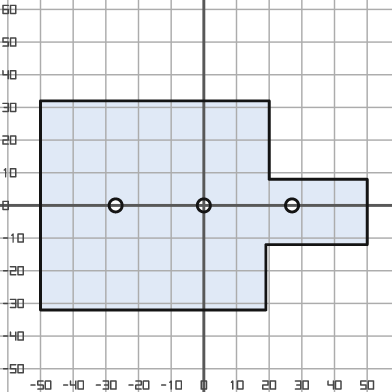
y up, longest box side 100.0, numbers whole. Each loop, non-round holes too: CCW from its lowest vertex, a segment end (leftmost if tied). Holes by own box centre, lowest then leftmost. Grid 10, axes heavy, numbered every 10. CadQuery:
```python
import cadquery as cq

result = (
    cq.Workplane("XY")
    .moveTo(-50.0, -32.0)
    .lineTo(19.0, -32.0)
    .lineTo(19.0, -12.0)
    .lineTo(50.0, -12.0)
    .lineTo(50.0, 8.0)
    .lineTo(20.0, 8.0)
    .lineTo(20.0, 32.0)
    .lineTo(-50.0, 32.0)
    .close()
    .moveTo(-27.0, 0.0)
    .circle(2.0)
    .moveTo(0.0, 0.0)
    .circle(2.0)
    .moveTo(27.0, 0.0)
    .circle(2.0)
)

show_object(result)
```